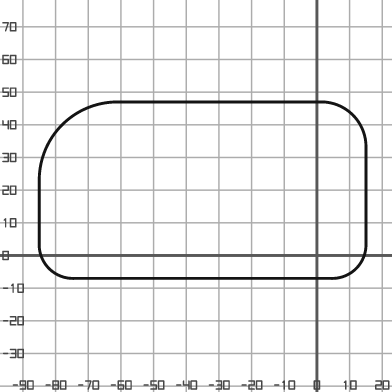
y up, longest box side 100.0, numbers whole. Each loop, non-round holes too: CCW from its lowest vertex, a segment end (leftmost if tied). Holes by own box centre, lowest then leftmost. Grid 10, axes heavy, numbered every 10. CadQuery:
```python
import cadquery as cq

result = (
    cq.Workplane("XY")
    .moveTo(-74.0, -7.0)
    .lineTo(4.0, -7.0)
    .threePointArc((12.0, -4.0), (15.0, 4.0))
    .lineTo(15.0, 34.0)
    .threePointArc((11.0, 43.0), (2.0, 47.0))
    .lineTo(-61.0, 47.0)
    .threePointArc((-78.0, 40.0), (-85.0, 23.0))
    .lineTo(-85.0, 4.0)
    .threePointArc((-82.0, -4.0), (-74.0, -7.0))
    .close()
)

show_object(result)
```